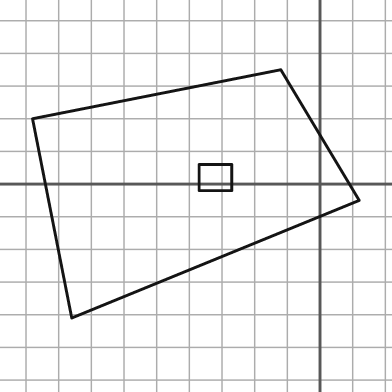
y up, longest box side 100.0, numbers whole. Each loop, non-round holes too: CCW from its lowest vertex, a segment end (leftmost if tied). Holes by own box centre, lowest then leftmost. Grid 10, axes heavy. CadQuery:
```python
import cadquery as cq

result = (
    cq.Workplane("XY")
    .moveTo(-76.0, -41.0)
    .lineTo(12.0, -5.0)
    .lineTo(-12.0, 35.0)
    .lineTo(-88.0, 20.0)
    .close()
    .moveTo(-37.0, -2.0)
    .lineTo(-27.0, -2.0)
    .lineTo(-27.0, 6.0)
    .lineTo(-37.0, 6.0)
    .close()
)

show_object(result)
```